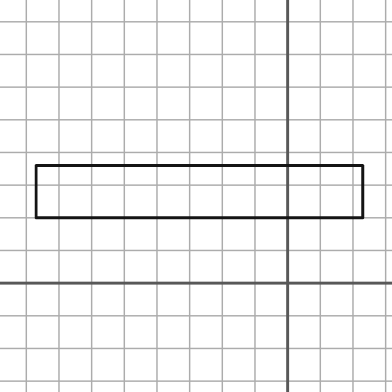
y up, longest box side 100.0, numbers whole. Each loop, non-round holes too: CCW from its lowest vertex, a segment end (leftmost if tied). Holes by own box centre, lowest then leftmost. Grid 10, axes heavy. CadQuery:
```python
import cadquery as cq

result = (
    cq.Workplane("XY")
    .moveTo(-77.0, 20.0)
    .lineTo(23.0, 20.0)
    .lineTo(23.0, 36.0)
    .lineTo(-77.0, 36.0)
    .close()
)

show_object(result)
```